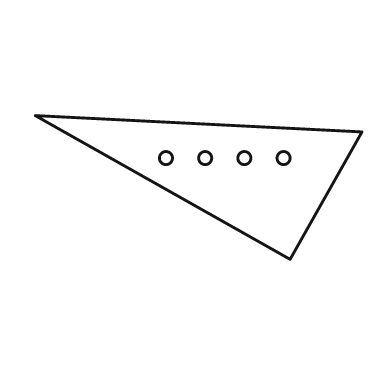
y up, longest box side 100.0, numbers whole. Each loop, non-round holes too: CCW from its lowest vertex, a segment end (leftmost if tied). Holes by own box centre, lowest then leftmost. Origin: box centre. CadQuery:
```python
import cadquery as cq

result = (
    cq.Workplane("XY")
    .moveTo(28.0, -22.0)
    .lineTo(50.0, 17.0)
    .lineTo(-50.0, 22.0)
    .close()
    .moveTo(-10.0, 9.0)
    .circle(2.0)
    .moveTo(2.0, 9.0)
    .circle(2.0)
    .moveTo(14.0, 9.0)
    .circle(2.0)
    .moveTo(26.0, 9.0)
    .circle(2.0)
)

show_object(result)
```